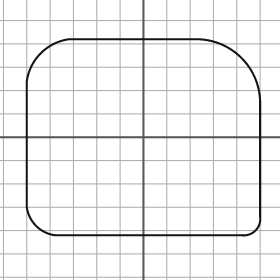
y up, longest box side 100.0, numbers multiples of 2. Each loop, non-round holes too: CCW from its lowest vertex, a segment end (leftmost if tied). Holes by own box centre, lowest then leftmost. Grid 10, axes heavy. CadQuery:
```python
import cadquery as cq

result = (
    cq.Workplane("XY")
    .moveTo(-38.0, -42.0)
    .lineTo(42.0, -42.0)
    .threePointArc((48.0, -40.0), (50.0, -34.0))
    .lineTo(50.0, 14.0)
    .threePointArc((42.0, 34.0), (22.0, 42.0))
    .lineTo(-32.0, 42.0)
    .threePointArc((-44.0, 36.0), (-50.0, 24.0))
    .lineTo(-50.0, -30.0)
    .threePointArc((-46.0, -38.0), (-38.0, -42.0))
    .close()
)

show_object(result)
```